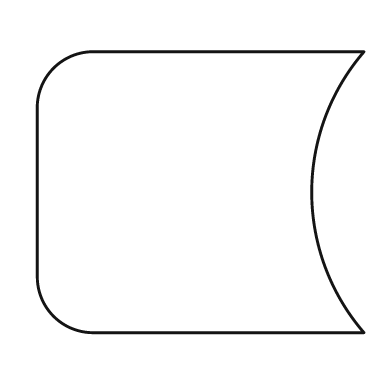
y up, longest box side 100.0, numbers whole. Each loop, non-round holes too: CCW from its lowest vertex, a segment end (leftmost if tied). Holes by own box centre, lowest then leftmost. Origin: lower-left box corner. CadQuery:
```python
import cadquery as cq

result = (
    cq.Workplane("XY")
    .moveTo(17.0, 0.0)
    .lineTo(100.0, 0.0)
    .threePointArc((84.0, 43.0), (100.0, 86.0))
    .lineTo(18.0, 86.0)
    .threePointArc((5.0, 81.0), (0.0, 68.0))
    .lineTo(0.0, 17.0)
    .threePointArc((5.0, 5.0), (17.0, 0.0))
    .close()
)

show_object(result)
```